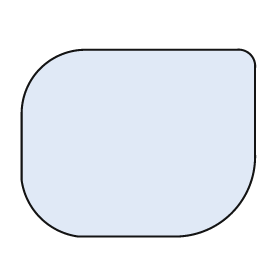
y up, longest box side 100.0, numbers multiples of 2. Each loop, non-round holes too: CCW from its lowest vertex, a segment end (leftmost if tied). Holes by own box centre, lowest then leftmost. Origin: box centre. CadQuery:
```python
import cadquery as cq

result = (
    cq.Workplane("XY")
    .moveTo(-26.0, -40.0)
    .lineTo(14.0, -40.0)
    .threePointArc((40.0, -30.0), (50.0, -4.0))
    .lineTo(50.0, 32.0)
    .threePointArc((48.0, 38.0), (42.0, 40.0))
    .lineTo(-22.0, 40.0)
    .threePointArc((-42.0, 32.0), (-50.0, 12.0))
    .lineTo(-50.0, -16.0)
    .threePointArc((-42.0, -32.0), (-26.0, -40.0))
    .close()
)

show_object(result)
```